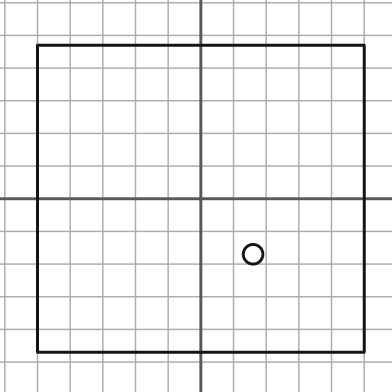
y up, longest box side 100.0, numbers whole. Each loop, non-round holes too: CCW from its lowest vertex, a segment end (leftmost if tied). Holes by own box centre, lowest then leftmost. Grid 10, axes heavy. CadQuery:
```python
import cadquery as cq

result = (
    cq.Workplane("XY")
    .moveTo(-50.0, -47.0)
    .lineTo(50.0, -47.0)
    .lineTo(50.0, 47.0)
    .lineTo(-50.0, 47.0)
    .close()
    .moveTo(16.0, -17.0)
    .circle(3.0)
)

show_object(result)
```